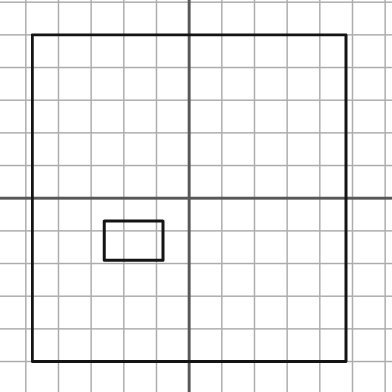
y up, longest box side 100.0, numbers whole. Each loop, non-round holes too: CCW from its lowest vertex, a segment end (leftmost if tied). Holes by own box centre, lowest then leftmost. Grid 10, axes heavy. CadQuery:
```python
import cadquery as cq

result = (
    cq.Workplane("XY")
    .moveTo(-48.0, -50.0)
    .lineTo(48.0, -50.0)
    .lineTo(48.0, 50.0)
    .lineTo(-48.0, 50.0)
    .close()
    .moveTo(-26.0, -19.0)
    .lineTo(-8.0, -19.0)
    .lineTo(-8.0, -7.0)
    .lineTo(-26.0, -7.0)
    .close()
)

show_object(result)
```